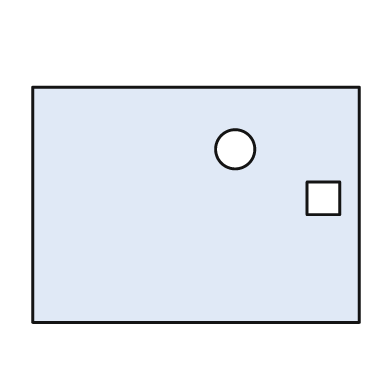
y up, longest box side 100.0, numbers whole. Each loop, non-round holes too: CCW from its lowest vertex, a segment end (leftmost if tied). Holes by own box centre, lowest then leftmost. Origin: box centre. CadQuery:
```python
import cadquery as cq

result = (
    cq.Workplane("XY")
    .moveTo(-50.0, -36.0)
    .lineTo(50.0, -36.0)
    .lineTo(50.0, 36.0)
    .lineTo(-50.0, 36.0)
    .close()
    .moveTo(34.0, -3.0)
    .lineTo(44.0, -3.0)
    .lineTo(44.0, 7.0)
    .lineTo(34.0, 7.0)
    .close()
    .moveTo(12.0, 17.0)
    .circle(6.0)
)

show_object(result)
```